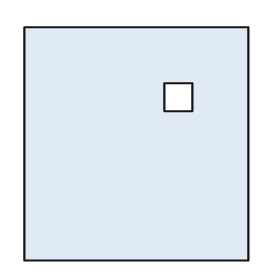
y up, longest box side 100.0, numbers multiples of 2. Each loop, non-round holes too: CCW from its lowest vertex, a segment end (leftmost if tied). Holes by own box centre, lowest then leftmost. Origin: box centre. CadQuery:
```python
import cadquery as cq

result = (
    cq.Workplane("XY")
    .moveTo(-48.0, -50.0)
    .lineTo(48.0, -50.0)
    .lineTo(48.0, 50.0)
    .lineTo(-48.0, 50.0)
    .close()
    .moveTo(12.0, 14.0)
    .lineTo(24.0, 14.0)
    .lineTo(24.0, 26.0)
    .lineTo(12.0, 26.0)
    .close()
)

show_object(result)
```